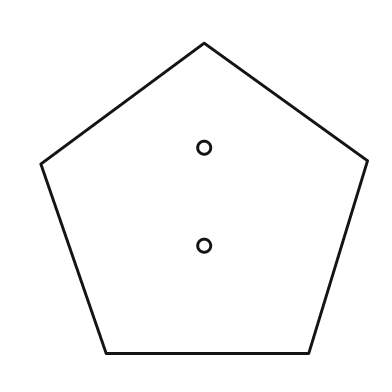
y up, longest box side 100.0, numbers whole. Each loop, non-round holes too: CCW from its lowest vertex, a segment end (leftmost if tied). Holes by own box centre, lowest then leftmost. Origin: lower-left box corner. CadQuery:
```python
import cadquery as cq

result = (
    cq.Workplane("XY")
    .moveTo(20.0, 0.0)
    .lineTo(82.0, 0.0)
    .lineTo(100.0, 59.0)
    .lineTo(50.0, 95.0)
    .lineTo(0.0, 58.0)
    .close()
    .moveTo(50.0, 33.0)
    .circle(2.0)
    .moveTo(50.0, 63.0)
    .circle(2.0)
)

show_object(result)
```